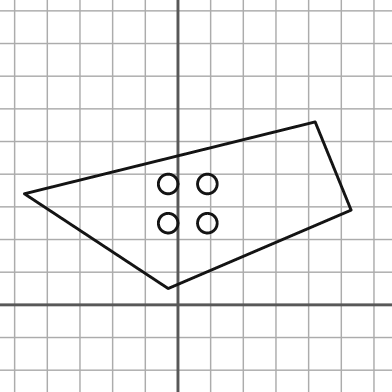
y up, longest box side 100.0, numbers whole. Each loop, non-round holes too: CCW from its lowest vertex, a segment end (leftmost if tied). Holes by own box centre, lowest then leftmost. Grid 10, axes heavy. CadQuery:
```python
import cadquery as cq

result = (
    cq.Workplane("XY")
    .moveTo(-3.0, 5.0)
    .lineTo(53.0, 29.0)
    .lineTo(42.0, 56.0)
    .lineTo(-47.0, 34.0)
    .close()
    .moveTo(-3.0, 25.0)
    .circle(3.0)
    .moveTo(9.0, 25.0)
    .circle(3.0)
    .moveTo(-3.0, 37.0)
    .circle(3.0)
    .moveTo(9.0, 37.0)
    .circle(3.0)
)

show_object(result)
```